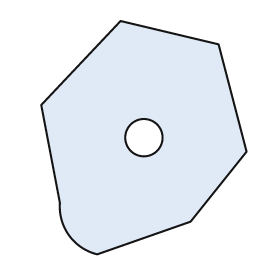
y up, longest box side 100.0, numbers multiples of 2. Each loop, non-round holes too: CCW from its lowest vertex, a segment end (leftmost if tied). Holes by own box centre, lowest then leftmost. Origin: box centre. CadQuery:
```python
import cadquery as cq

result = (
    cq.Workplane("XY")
    .moveTo(-20.0, -50.0)
    .lineTo(20.0, -36.0)
    .lineTo(44.0, -6.0)
    .lineTo(32.0, 40.0)
    .lineTo(-10.0, 50.0)
    .lineTo(-44.0, 14.0)
    .lineTo(-36.0, -28.0)
    .threePointArc((-32.0, -42.0), (-20.0, -50.0))
    .close()
    .moveTo(0.0, 0.0)
    .circle(8.0)
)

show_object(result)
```